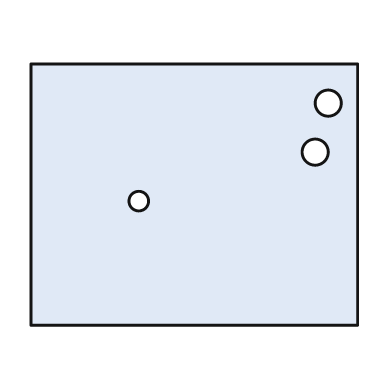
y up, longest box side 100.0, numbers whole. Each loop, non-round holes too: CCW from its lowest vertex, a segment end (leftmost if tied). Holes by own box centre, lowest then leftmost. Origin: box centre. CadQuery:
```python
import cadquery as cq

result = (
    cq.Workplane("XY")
    .moveTo(-50.0, -40.0)
    .lineTo(50.0, -40.0)
    .lineTo(50.0, 40.0)
    .lineTo(-50.0, 40.0)
    .close()
    .moveTo(-17.0, -2.0)
    .circle(3.0)
    .moveTo(37.0, 13.0)
    .circle(4.0)
    .moveTo(41.0, 28.0)
    .circle(4.0)
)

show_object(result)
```